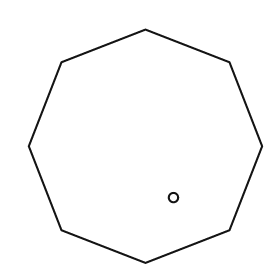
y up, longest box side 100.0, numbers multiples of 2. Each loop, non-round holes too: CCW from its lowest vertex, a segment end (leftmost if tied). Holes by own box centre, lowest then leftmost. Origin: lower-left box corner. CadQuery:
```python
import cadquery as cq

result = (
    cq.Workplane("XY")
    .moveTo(50.0, 0.0)
    .lineTo(86.0, 14.0)
    .lineTo(100.0, 50.0)
    .lineTo(86.0, 86.0)
    .lineTo(50.0, 100.0)
    .lineTo(14.0, 86.0)
    .lineTo(0.0, 50.0)
    .lineTo(14.0, 14.0)
    .close()
    .moveTo(62.0, 28.0)
    .circle(2.0)
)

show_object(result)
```